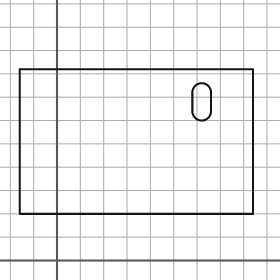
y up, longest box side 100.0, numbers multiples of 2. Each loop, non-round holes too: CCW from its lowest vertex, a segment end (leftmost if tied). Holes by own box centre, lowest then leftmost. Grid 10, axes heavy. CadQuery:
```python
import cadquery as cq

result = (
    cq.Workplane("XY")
    .moveTo(-16.0, 20.0)
    .lineTo(84.0, 20.0)
    .lineTo(84.0, 82.0)
    .lineTo(-16.0, 82.0)
    .close()
    .moveTo(58.0, 64.0)
    .threePointArc((62.0, 60.0), (66.0, 64.0))
    .lineTo(66.0, 72.0)
    .threePointArc((62.0, 76.0), (58.0, 72.0))
    .close()
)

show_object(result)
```